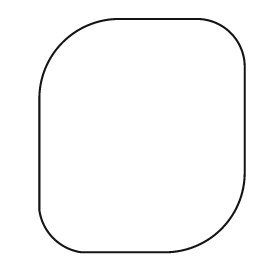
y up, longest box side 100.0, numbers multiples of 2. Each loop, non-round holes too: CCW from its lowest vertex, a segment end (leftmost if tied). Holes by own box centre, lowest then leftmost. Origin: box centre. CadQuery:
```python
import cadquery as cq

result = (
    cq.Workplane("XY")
    .moveTo(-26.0, -50.0)
    .lineTo(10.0, -50.0)
    .threePointArc((34.0, -40.0), (44.0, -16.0))
    .lineTo(44.0, 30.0)
    .threePointArc((38.0, 44.0), (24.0, 50.0))
    .lineTo(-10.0, 50.0)
    .threePointArc((-34.0, 40.0), (-44.0, 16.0))
    .lineTo(-44.0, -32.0)
    .threePointArc((-38.0, -44.0), (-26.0, -50.0))
    .close()
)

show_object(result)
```